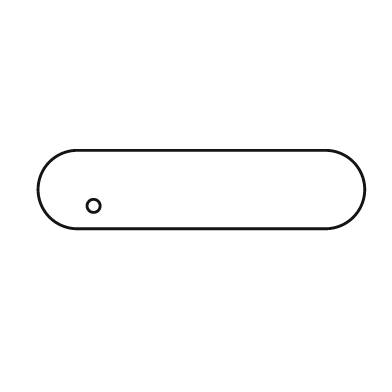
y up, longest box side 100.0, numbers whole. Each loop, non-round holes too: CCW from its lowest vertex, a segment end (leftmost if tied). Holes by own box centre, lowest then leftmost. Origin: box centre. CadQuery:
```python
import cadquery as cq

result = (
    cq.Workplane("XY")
    .moveTo(-38.0, -12.0)
    .lineTo(38.0, -12.0)
    .threePointArc((50.0, 0.0), (38.0, 12.0))
    .lineTo(-38.0, 12.0)
    .threePointArc((-50.0, 0.0), (-38.0, -12.0))
    .close()
    .moveTo(-33.0, -5.0)
    .circle(2.0)
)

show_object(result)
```